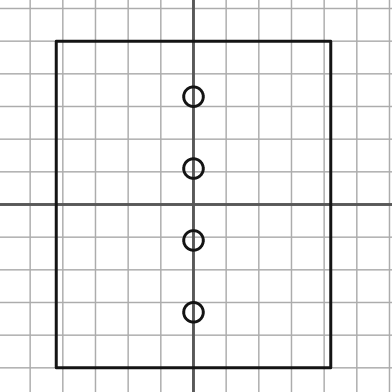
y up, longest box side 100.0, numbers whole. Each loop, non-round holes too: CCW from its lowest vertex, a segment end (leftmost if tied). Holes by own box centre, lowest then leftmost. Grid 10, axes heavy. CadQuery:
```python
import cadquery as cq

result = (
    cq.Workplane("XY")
    .moveTo(-42.0, -50.0)
    .lineTo(42.0, -50.0)
    .lineTo(42.0, 50.0)
    .lineTo(-42.0, 50.0)
    .close()
    .moveTo(0.0, -33.0)
    .circle(3.0)
    .moveTo(0.0, -11.0)
    .circle(3.0)
    .moveTo(0.0, 11.0)
    .circle(3.0)
    .moveTo(0.0, 33.0)
    .circle(3.0)
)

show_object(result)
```